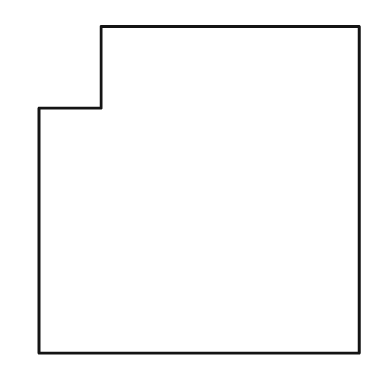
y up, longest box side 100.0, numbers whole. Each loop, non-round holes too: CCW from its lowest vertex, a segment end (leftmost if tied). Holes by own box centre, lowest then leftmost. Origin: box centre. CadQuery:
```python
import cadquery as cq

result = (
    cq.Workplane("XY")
    .moveTo(-49.0, -50.0)
    .lineTo(49.0, -50.0)
    .lineTo(49.0, 50.0)
    .lineTo(-30.0, 50.0)
    .lineTo(-30.0, 25.0)
    .lineTo(-49.0, 25.0)
    .close()
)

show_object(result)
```